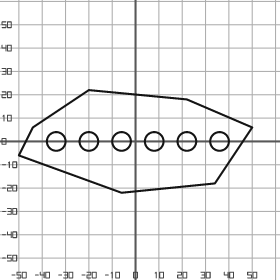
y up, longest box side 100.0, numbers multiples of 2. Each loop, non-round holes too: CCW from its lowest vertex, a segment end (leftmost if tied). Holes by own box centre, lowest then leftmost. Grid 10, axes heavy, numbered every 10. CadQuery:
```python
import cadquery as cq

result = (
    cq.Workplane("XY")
    .moveTo(-6.0, -22.0)
    .lineTo(34.0, -18.0)
    .lineTo(50.0, 6.0)
    .lineTo(22.0, 18.0)
    .lineTo(-20.0, 22.0)
    .lineTo(-44.0, 6.0)
    .lineTo(-50.0, -6.0)
    .close()
    .moveTo(-34.0, 0.0)
    .circle(4.0)
    .moveTo(-20.0, 0.0)
    .circle(4.0)
    .moveTo(-6.0, 0.0)
    .circle(4.0)
    .moveTo(8.0, 0.0)
    .circle(4.0)
    .moveTo(22.0, 0.0)
    .circle(4.0)
    .moveTo(36.0, 0.0)
    .circle(4.0)
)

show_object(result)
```